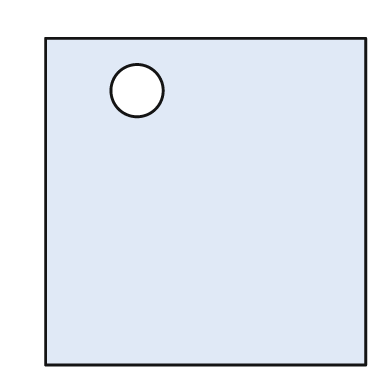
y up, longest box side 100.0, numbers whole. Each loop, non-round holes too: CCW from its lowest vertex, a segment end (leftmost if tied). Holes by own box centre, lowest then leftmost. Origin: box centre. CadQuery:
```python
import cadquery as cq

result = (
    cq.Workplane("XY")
    .moveTo(-49.0, -50.0)
    .lineTo(49.0, -50.0)
    .lineTo(49.0, 50.0)
    .lineTo(-49.0, 50.0)
    .close()
    .moveTo(-21.0, 34.0)
    .circle(8.0)
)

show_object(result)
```